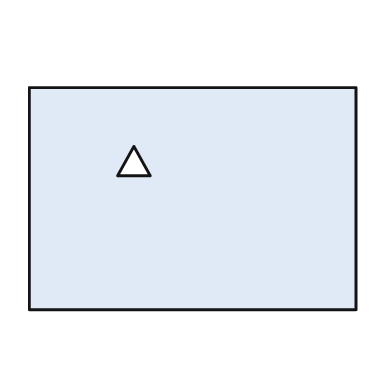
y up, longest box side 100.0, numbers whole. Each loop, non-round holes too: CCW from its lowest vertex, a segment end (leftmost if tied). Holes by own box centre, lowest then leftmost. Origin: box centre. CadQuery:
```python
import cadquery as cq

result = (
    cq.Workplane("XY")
    .moveTo(-50.0, -34.0)
    .lineTo(50.0, -34.0)
    .lineTo(50.0, 34.0)
    .lineTo(-50.0, 34.0)
    .close()
    .moveTo(-23.0, 7.0)
    .lineTo(-13.0, 7.0)
    .lineTo(-18.0, 16.0)
    .close()
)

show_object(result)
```